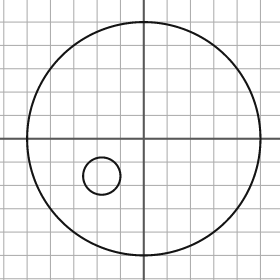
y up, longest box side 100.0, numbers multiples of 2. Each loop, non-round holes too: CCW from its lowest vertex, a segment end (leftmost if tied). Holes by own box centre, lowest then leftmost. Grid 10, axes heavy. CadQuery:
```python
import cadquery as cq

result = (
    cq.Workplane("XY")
    .moveTo(0.0, 0.0)
    .circle(50.0)
    .moveTo(-18.0, -16.0)
    .circle(8.0)
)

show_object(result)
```